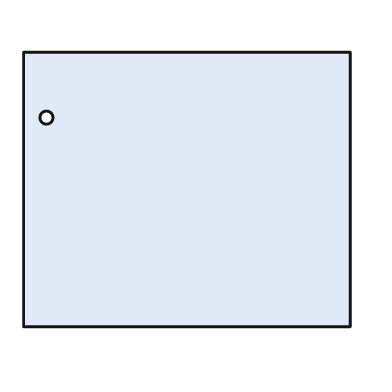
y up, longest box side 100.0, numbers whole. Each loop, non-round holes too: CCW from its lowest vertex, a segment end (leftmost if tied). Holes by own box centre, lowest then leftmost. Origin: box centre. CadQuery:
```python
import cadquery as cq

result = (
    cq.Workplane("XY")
    .moveTo(-50.0, -42.0)
    .lineTo(50.0, -42.0)
    .lineTo(50.0, 42.0)
    .lineTo(-50.0, 42.0)
    .close()
    .moveTo(-43.0, 22.0)
    .circle(2.0)
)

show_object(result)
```